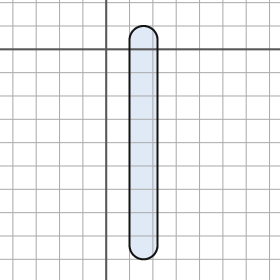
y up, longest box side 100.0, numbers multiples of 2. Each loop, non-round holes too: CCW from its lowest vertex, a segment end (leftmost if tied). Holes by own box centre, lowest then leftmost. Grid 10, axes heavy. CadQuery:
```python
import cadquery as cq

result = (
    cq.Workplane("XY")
    .moveTo(10.0, -84.0)
    .threePointArc((16.0, -90.0), (22.0, -84.0))
    .lineTo(22.0, 4.0)
    .threePointArc((16.0, 10.0), (10.0, 4.0))
    .close()
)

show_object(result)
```